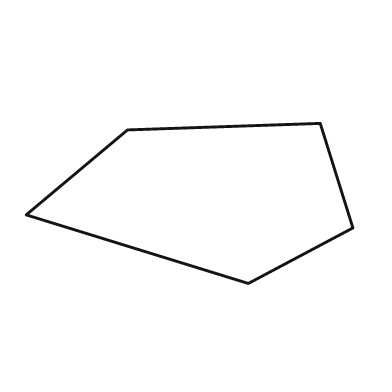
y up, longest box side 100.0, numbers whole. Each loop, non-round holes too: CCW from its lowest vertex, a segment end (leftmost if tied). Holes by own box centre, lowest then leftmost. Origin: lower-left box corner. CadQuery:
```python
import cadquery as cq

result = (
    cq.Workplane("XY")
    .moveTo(68.0, 0.0)
    .lineTo(100.0, 17.0)
    .lineTo(90.0, 49.0)
    .lineTo(31.0, 47.0)
    .lineTo(0.0, 21.0)
    .close()
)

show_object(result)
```